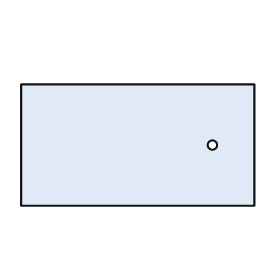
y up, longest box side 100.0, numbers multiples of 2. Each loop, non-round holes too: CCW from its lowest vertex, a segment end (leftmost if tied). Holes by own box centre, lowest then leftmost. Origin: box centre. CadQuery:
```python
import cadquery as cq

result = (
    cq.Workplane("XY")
    .moveTo(-50.0, -26.0)
    .lineTo(50.0, -26.0)
    .lineTo(50.0, 26.0)
    .lineTo(-50.0, 26.0)
    .close()
    .moveTo(32.0, 0.0)
    .circle(2.0)
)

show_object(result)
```